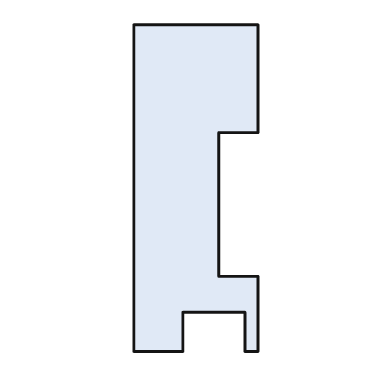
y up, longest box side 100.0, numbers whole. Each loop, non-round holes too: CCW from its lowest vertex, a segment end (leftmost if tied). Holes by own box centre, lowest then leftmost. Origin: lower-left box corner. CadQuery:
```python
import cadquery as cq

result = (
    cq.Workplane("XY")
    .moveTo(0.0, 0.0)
    .lineTo(15.0, 0.0)
    .lineTo(15.0, 12.0)
    .lineTo(34.0, 12.0)
    .lineTo(34.0, 0.0)
    .lineTo(38.0, 0.0)
    .lineTo(38.0, 23.0)
    .lineTo(26.0, 23.0)
    .lineTo(26.0, 67.0)
    .lineTo(38.0, 67.0)
    .lineTo(38.0, 100.0)
    .lineTo(0.0, 100.0)
    .close()
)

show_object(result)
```